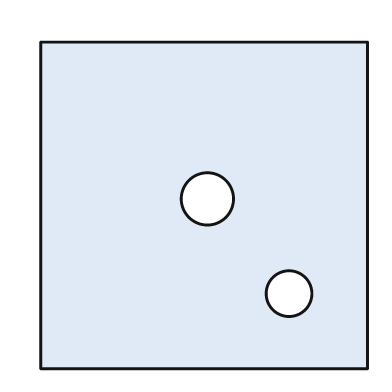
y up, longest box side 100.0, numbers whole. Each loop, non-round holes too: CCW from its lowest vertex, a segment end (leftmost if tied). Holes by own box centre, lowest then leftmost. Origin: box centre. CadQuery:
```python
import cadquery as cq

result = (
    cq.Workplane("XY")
    .moveTo(-50.0, -50.0)
    .lineTo(50.0, -50.0)
    .lineTo(50.0, 50.0)
    .lineTo(-50.0, 50.0)
    .close()
    .moveTo(26.0, -27.0)
    .circle(7.0)
    .moveTo(1.0, 2.0)
    .circle(8.0)
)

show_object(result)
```